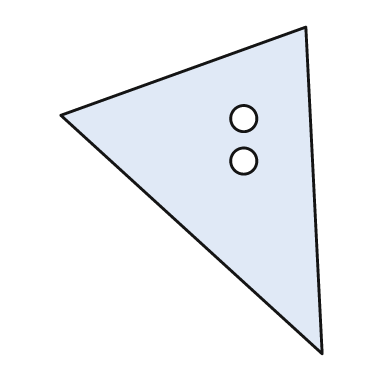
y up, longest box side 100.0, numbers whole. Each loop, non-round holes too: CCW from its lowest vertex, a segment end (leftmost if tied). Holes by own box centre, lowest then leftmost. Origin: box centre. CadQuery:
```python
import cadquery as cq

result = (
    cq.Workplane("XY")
    .moveTo(40.0, -50.0)
    .lineTo(35.0, 50.0)
    .lineTo(-40.0, 23.0)
    .close()
    .moveTo(16.0, 9.0)
    .circle(4.0)
    .moveTo(16.0, 22.0)
    .circle(4.0)
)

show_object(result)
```